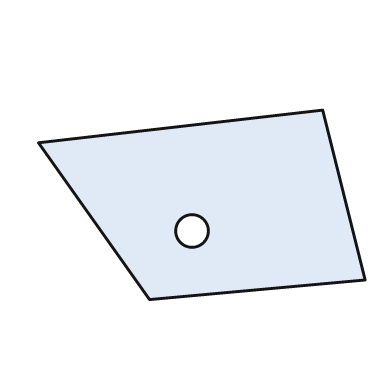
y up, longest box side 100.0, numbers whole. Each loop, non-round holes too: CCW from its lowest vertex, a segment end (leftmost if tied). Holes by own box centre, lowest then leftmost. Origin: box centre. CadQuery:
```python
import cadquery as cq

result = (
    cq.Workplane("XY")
    .moveTo(-16.0, -29.0)
    .lineTo(50.0, -23.0)
    .lineTo(37.0, 29.0)
    .lineTo(-50.0, 19.0)
    .close()
    .moveTo(-3.0, -8.0)
    .circle(5.0)
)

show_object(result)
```